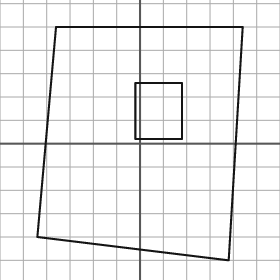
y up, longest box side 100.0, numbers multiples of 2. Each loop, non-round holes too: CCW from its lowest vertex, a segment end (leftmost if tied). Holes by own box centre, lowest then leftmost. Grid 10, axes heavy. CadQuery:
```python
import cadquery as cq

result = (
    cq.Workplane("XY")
    .moveTo(38.0, -50.0)
    .lineTo(44.0, 50.0)
    .lineTo(-36.0, 50.0)
    .lineTo(-44.0, -40.0)
    .close()
    .moveTo(-2.0, 2.0)
    .lineTo(18.0, 2.0)
    .lineTo(18.0, 26.0)
    .lineTo(-2.0, 26.0)
    .close()
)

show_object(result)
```